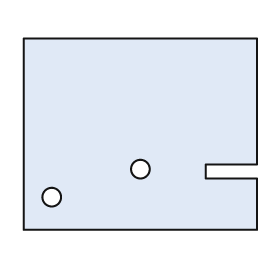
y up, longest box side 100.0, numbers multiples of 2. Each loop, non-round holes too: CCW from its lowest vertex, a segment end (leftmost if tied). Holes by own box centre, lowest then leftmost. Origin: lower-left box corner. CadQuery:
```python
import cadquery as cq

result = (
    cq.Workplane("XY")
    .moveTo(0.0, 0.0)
    .lineTo(100.0, 0.0)
    .lineTo(100.0, 22.0)
    .lineTo(78.0, 22.0)
    .lineTo(78.0, 28.0)
    .lineTo(100.0, 28.0)
    .lineTo(100.0, 82.0)
    .lineTo(0.0, 82.0)
    .close()
    .moveTo(12.0, 14.0)
    .circle(4.0)
    .moveTo(50.0, 26.0)
    .circle(4.0)
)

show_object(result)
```